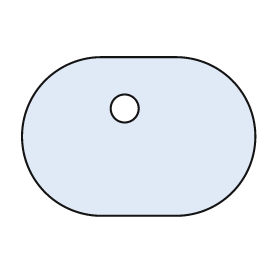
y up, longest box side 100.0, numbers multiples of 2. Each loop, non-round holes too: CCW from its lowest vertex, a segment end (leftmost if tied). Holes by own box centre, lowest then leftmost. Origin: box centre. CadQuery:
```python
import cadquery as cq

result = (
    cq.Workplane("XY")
    .moveTo(-16.0, -34.0)
    .lineTo(16.0, -34.0)
    .threePointArc((50.0, 0.0), (16.0, 34.0))
    .lineTo(-16.0, 34.0)
    .threePointArc((-50.0, 0.0), (-16.0, -34.0))
    .close()
    .moveTo(-6.0, 12.0)
    .circle(6.0)
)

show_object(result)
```